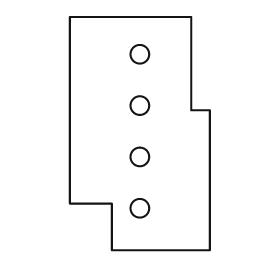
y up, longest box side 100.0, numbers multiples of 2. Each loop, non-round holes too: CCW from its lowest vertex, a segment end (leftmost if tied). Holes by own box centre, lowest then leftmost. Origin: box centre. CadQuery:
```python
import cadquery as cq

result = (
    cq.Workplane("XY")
    .moveTo(-12.0, -50.0)
    .lineTo(30.0, -50.0)
    .lineTo(30.0, 10.0)
    .lineTo(22.0, 10.0)
    .lineTo(22.0, 50.0)
    .lineTo(-30.0, 50.0)
    .lineTo(-30.0, -30.0)
    .lineTo(-12.0, -30.0)
    .close()
    .moveTo(0.0, -32.0)
    .circle(4.0)
    .moveTo(0.0, -10.0)
    .circle(4.0)
    .moveTo(0.0, 12.0)
    .circle(4.0)
    .moveTo(0.0, 34.0)
    .circle(4.0)
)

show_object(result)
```